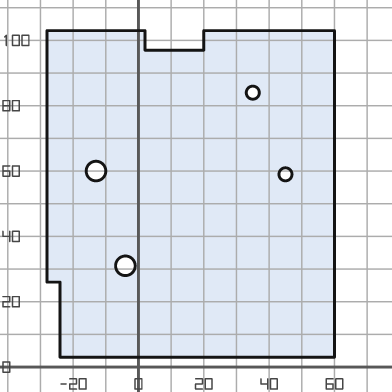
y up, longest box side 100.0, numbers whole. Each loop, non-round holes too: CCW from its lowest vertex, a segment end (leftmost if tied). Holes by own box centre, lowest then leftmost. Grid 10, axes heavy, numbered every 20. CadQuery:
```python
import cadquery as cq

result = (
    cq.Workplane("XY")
    .moveTo(-24.0, 3.0)
    .lineTo(60.0, 3.0)
    .lineTo(60.0, 103.0)
    .lineTo(20.0, 103.0)
    .lineTo(20.0, 97.0)
    .lineTo(2.0, 97.0)
    .lineTo(2.0, 103.0)
    .lineTo(-28.0, 103.0)
    .lineTo(-28.0, 26.0)
    .lineTo(-24.0, 26.0)
    .close()
    .moveTo(-4.0, 31.0)
    .circle(3.0)
    .moveTo(45.0, 59.0)
    .circle(2.0)
    .moveTo(-13.0, 60.0)
    .circle(3.0)
    .moveTo(35.0, 84.0)
    .circle(2.0)
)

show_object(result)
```